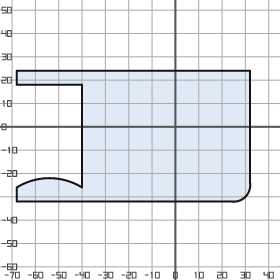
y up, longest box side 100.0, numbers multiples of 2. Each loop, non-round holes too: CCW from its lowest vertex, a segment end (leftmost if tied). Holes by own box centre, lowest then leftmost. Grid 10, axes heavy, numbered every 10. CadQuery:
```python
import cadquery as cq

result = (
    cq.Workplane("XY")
    .moveTo(-68.0, -32.0)
    .lineTo(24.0, -32.0)
    .threePointArc((30.0, -30.0), (32.0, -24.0))
    .lineTo(32.0, 24.0)
    .lineTo(-68.0, 24.0)
    .lineTo(-68.0, 18.0)
    .lineTo(-40.0, 18.0)
    .lineTo(-40.0, -26.0)
    .threePointArc((-54.0, -22.0), (-68.0, -26.0))
    .close()
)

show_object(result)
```